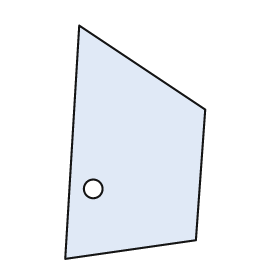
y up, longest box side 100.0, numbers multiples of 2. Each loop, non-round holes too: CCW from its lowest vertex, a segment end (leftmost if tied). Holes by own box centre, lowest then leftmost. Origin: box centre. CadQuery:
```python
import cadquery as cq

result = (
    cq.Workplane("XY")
    .moveTo(-30.0, -50.0)
    .lineTo(26.0, -42.0)
    .lineTo(30.0, 14.0)
    .lineTo(-24.0, 50.0)
    .close()
    .moveTo(-18.0, -20.0)
    .circle(4.0)
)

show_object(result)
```